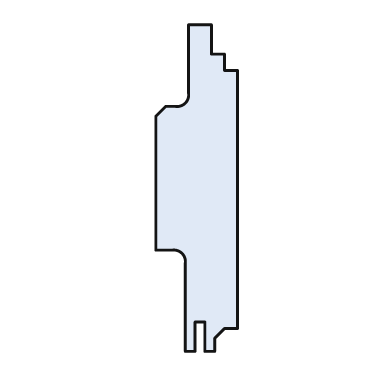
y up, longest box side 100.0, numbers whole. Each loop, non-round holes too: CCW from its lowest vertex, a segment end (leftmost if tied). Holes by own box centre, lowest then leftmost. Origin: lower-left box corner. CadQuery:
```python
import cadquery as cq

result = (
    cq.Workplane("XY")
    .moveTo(9.0, 0.0)
    .lineTo(12.0, 0.0)
    .lineTo(12.0, 9.0)
    .lineTo(15.0, 9.0)
    .lineTo(15.0, 0.0)
    .lineTo(18.0, 0.0)
    .lineTo(18.0, 4.0)
    .lineTo(21.0, 7.0)
    .lineTo(25.0, 7.0)
    .lineTo(25.0, 86.0)
    .lineTo(21.0, 86.0)
    .lineTo(21.0, 91.0)
    .lineTo(17.0, 91.0)
    .lineTo(17.0, 100.0)
    .lineTo(10.0, 100.0)
    .lineTo(10.0, 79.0)
    .threePointArc((9.0, 76.0), (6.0, 75.0))
    .lineTo(3.0, 75.0)
    .lineTo(0.0, 72.0)
    .lineTo(0.0, 31.0)
    .lineTo(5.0, 31.0)
    .threePointArc((8.0, 30.0), (9.0, 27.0))
    .close()
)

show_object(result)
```